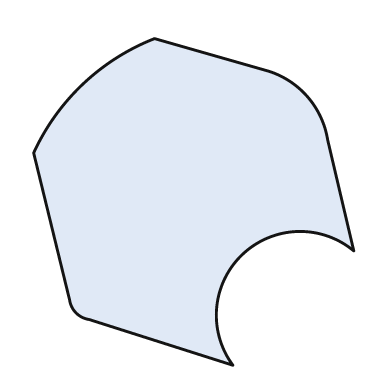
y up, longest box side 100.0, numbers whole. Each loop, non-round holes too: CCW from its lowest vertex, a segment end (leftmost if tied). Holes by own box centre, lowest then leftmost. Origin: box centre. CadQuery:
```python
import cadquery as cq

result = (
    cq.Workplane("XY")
    .moveTo(12.0, -50.0)
    .threePointArc((15.0, -16.0), (49.0, -15.0))
    .lineTo(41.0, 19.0)
    .threePointArc((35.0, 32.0), (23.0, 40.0))
    .lineTo(-12.0, 50.0)
    .threePointArc((-34.0, 36.0), (-49.0, 15.0))
    .lineTo(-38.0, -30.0)
    .threePointArc((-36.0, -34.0), (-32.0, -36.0))
    .close()
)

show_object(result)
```